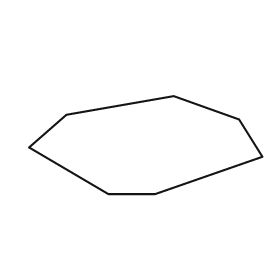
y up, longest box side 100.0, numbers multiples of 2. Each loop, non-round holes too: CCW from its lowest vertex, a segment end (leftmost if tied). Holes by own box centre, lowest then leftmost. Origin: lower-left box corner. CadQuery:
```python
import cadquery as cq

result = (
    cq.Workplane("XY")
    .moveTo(34.0, 0.0)
    .lineTo(54.0, 0.0)
    .lineTo(100.0, 16.0)
    .lineTo(90.0, 32.0)
    .lineTo(62.0, 42.0)
    .lineTo(16.0, 34.0)
    .lineTo(0.0, 20.0)
    .close()
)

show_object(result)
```